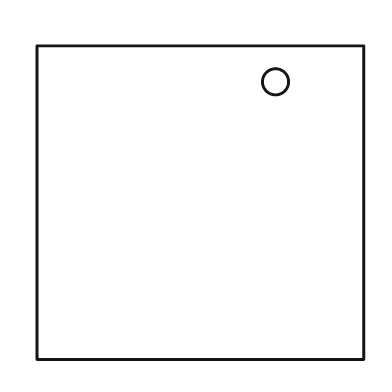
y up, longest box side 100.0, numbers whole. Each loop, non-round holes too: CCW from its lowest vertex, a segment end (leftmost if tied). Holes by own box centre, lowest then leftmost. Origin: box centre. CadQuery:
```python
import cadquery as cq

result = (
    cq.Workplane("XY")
    .moveTo(-50.0, -48.0)
    .lineTo(50.0, -48.0)
    .lineTo(50.0, 48.0)
    .lineTo(-50.0, 48.0)
    .close()
    .moveTo(23.0, 37.0)
    .circle(4.0)
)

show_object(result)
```